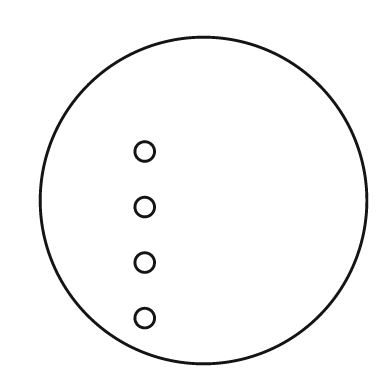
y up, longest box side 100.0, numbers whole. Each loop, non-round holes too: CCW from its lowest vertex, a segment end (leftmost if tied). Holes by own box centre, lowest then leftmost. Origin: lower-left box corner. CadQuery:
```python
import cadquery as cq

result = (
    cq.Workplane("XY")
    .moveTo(50.0, 50.0)
    .circle(50.0)
    .moveTo(32.0, 14.0)
    .circle(3.0)
    .moveTo(32.0, 31.0)
    .circle(3.0)
    .moveTo(32.0, 48.0)
    .circle(3.0)
    .moveTo(32.0, 65.0)
    .circle(3.0)
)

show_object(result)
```